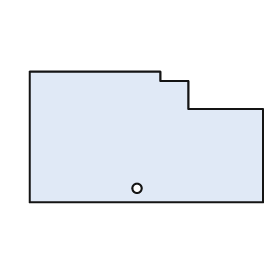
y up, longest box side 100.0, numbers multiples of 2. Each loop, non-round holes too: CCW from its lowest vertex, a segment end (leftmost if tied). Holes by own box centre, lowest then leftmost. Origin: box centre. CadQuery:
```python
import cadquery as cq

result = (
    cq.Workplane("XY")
    .moveTo(-50.0, -28.0)
    .lineTo(50.0, -28.0)
    .lineTo(50.0, 12.0)
    .lineTo(18.0, 12.0)
    .lineTo(18.0, 24.0)
    .lineTo(6.0, 24.0)
    .lineTo(6.0, 28.0)
    .lineTo(-50.0, 28.0)
    .close()
    .moveTo(-4.0, -22.0)
    .circle(2.0)
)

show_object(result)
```